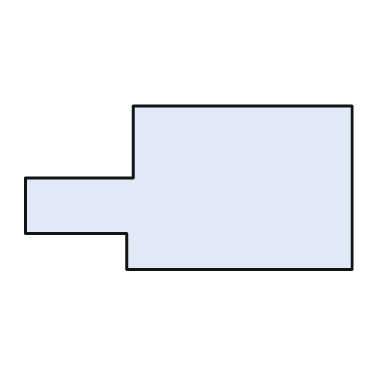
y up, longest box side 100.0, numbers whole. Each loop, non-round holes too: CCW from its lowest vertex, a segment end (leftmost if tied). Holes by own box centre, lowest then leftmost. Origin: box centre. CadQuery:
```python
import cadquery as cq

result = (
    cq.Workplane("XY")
    .moveTo(-19.0, -25.0)
    .lineTo(50.0, -25.0)
    .lineTo(50.0, 25.0)
    .lineTo(-17.0, 25.0)
    .lineTo(-17.0, 3.0)
    .lineTo(-50.0, 3.0)
    .lineTo(-50.0, -14.0)
    .lineTo(-19.0, -14.0)
    .close()
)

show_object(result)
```